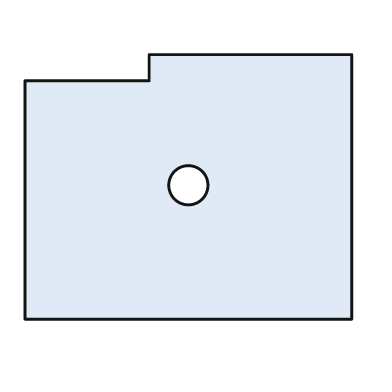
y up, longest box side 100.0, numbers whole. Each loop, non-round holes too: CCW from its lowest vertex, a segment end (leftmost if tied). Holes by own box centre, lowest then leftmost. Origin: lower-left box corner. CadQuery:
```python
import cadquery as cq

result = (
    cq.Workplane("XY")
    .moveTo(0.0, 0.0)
    .lineTo(100.0, 0.0)
    .lineTo(100.0, 81.0)
    .lineTo(38.0, 81.0)
    .lineTo(38.0, 73.0)
    .lineTo(0.0, 73.0)
    .close()
    .moveTo(50.0, 41.0)
    .circle(6.0)
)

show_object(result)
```